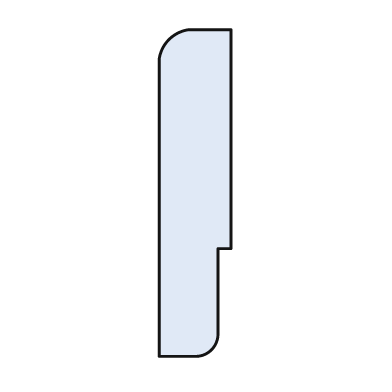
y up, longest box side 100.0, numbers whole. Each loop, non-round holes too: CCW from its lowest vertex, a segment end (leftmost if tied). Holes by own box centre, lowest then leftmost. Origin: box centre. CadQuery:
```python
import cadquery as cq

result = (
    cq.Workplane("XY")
    .moveTo(-11.0, -50.0)
    .lineTo(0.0, -50.0)
    .threePointArc((5.0, -48.0), (7.0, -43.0))
    .lineTo(7.0, -17.0)
    .lineTo(11.0, -17.0)
    .lineTo(11.0, 50.0)
    .lineTo(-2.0, 50.0)
    .threePointArc((-8.0, 47.0), (-11.0, 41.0))
    .close()
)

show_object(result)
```